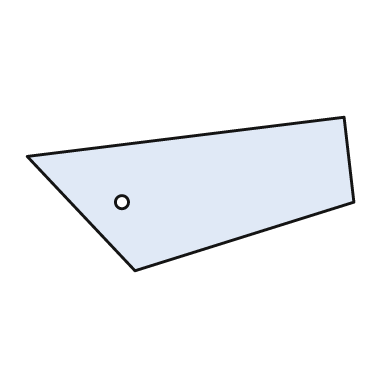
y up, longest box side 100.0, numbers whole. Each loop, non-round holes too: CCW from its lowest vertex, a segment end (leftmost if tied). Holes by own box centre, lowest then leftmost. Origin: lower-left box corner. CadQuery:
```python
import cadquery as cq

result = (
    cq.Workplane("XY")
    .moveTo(33.0, 0.0)
    .lineTo(100.0, 21.0)
    .lineTo(97.0, 47.0)
    .lineTo(0.0, 35.0)
    .close()
    .moveTo(29.0, 21.0)
    .circle(2.0)
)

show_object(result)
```